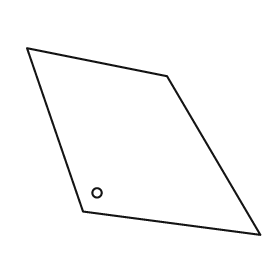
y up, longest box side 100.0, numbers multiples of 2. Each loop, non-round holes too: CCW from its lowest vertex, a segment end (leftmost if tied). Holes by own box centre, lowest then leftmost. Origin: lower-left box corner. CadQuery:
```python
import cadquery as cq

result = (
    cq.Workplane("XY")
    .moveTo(100.0, 0.0)
    .lineTo(60.0, 68.0)
    .lineTo(0.0, 80.0)
    .lineTo(24.0, 10.0)
    .close()
    .moveTo(30.0, 18.0)
    .circle(2.0)
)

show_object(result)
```